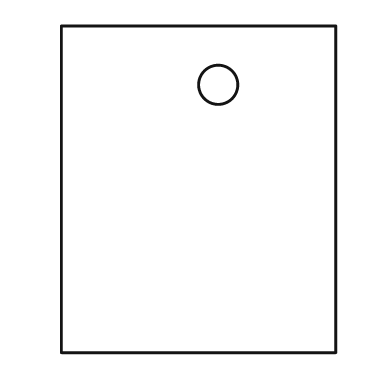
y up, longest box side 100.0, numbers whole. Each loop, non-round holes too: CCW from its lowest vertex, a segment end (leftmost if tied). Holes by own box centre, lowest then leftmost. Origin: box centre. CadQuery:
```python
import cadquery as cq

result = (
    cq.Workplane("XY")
    .moveTo(-42.0, -50.0)
    .lineTo(42.0, -50.0)
    .lineTo(42.0, 50.0)
    .lineTo(-42.0, 50.0)
    .close()
    .moveTo(6.0, 32.0)
    .circle(6.0)
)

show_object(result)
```